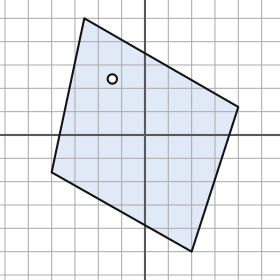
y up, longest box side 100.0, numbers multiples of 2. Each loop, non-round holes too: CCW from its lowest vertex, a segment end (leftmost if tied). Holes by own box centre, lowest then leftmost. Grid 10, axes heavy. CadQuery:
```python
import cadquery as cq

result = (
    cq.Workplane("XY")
    .moveTo(20.0, -50.0)
    .lineTo(40.0, 12.0)
    .lineTo(-26.0, 50.0)
    .lineTo(-40.0, -16.0)
    .close()
    .moveTo(-14.0, 24.0)
    .circle(2.0)
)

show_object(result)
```